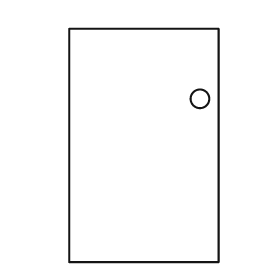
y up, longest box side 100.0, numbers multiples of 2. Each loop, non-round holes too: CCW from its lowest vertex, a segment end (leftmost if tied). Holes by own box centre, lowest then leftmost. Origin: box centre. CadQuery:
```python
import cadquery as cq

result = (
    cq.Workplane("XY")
    .moveTo(-32.0, -50.0)
    .lineTo(32.0, -50.0)
    .lineTo(32.0, 50.0)
    .lineTo(-32.0, 50.0)
    .close()
    .moveTo(24.0, 20.0)
    .circle(4.0)
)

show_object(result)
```